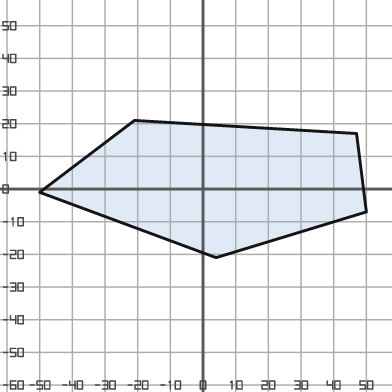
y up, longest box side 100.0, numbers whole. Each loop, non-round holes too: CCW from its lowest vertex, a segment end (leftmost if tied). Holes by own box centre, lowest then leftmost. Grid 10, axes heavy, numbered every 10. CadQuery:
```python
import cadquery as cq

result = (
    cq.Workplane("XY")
    .moveTo(4.0, -21.0)
    .lineTo(50.0, -7.0)
    .lineTo(47.0, 17.0)
    .lineTo(-21.0, 21.0)
    .lineTo(-50.0, -1.0)
    .close()
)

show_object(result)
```